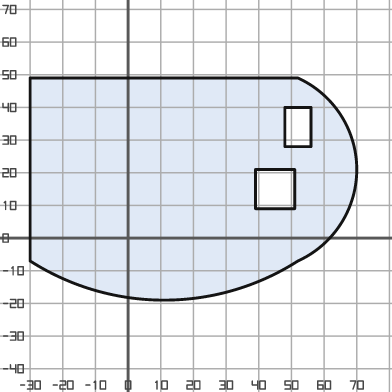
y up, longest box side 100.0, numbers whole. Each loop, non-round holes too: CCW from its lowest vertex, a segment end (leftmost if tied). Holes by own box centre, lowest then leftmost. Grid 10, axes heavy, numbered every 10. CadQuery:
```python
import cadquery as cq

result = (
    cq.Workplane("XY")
    .moveTo(-30.0, -7.0)
    .threePointArc((11.0, -19.0), (52.0, -7.0))
    .threePointArc((70.0, 21.0), (52.0, 49.0))
    .lineTo(-30.0, 49.0)
    .close()
    .moveTo(39.0, 9.0)
    .lineTo(51.0, 9.0)
    .lineTo(51.0, 21.0)
    .lineTo(39.0, 21.0)
    .close()
    .moveTo(48.0, 28.0)
    .lineTo(56.0, 28.0)
    .lineTo(56.0, 40.0)
    .lineTo(48.0, 40.0)
    .close()
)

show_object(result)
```